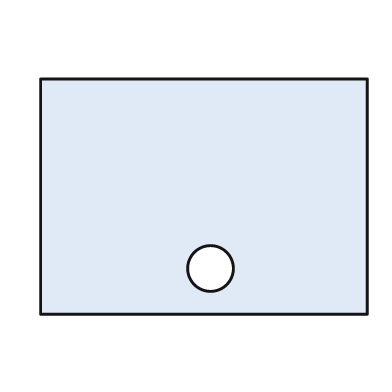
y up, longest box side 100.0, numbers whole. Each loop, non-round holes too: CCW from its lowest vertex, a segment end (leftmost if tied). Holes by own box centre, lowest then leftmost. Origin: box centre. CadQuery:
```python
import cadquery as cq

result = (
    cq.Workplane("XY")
    .moveTo(-50.0, -36.0)
    .lineTo(50.0, -36.0)
    .lineTo(50.0, 36.0)
    .lineTo(-50.0, 36.0)
    .close()
    .moveTo(2.0, -22.0)
    .circle(7.0)
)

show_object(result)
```